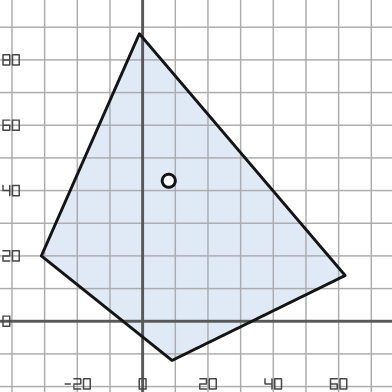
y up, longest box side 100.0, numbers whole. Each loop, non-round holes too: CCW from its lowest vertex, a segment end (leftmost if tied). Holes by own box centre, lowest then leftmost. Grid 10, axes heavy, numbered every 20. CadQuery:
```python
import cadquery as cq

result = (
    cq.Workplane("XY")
    .moveTo(9.0, -12.0)
    .lineTo(62.0, 14.0)
    .lineTo(-1.0, 88.0)
    .lineTo(-31.0, 20.0)
    .close()
    .moveTo(8.0, 43.0)
    .circle(2.0)
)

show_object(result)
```